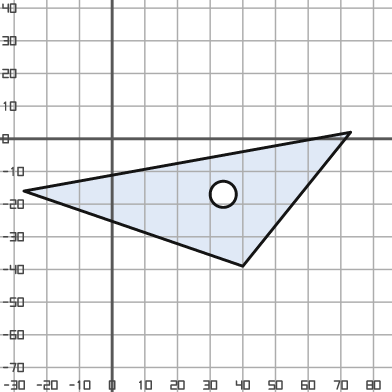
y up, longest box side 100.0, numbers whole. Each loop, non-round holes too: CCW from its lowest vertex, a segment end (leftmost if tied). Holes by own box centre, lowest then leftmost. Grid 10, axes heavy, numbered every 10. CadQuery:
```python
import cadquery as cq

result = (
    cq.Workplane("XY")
    .moveTo(40.0, -39.0)
    .lineTo(73.0, 2.0)
    .lineTo(-27.0, -16.0)
    .close()
    .moveTo(34.0, -17.0)
    .circle(4.0)
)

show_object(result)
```